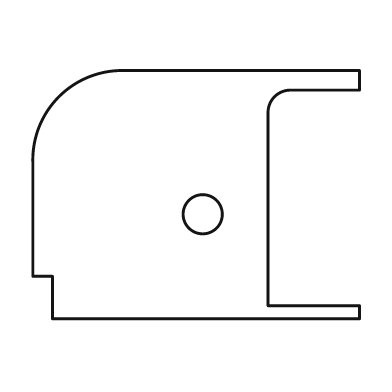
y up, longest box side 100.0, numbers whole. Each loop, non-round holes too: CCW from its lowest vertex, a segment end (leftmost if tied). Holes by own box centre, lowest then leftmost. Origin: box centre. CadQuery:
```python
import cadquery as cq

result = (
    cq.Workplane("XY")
    .moveTo(-44.0, -38.0)
    .lineTo(50.0, -38.0)
    .lineTo(50.0, -34.0)
    .lineTo(22.0, -34.0)
    .lineTo(22.0, 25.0)
    .threePointArc((24.0, 30.0), (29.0, 32.0))
    .lineTo(50.0, 32.0)
    .lineTo(50.0, 38.0)
    .lineTo(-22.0, 38.0)
    .threePointArc((-42.0, 30.0), (-50.0, 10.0))
    .lineTo(-50.0, -25.0)
    .lineTo(-44.0, -25.0)
    .close()
    .moveTo(2.0, -6.0)
    .circle(6.0)
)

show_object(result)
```